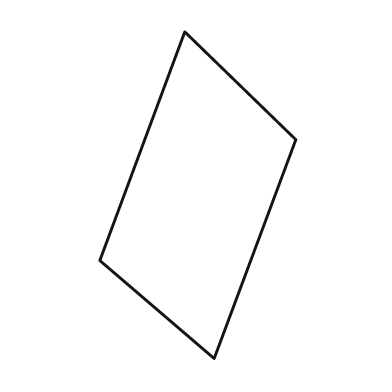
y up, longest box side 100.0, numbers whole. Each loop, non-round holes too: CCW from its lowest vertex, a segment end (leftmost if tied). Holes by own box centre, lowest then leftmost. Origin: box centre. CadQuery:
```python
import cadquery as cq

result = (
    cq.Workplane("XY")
    .moveTo(5.0, -50.0)
    .lineTo(30.0, 17.0)
    .lineTo(-4.0, 50.0)
    .lineTo(-30.0, -20.0)
    .close()
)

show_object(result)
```